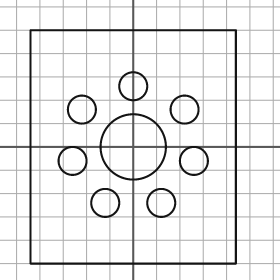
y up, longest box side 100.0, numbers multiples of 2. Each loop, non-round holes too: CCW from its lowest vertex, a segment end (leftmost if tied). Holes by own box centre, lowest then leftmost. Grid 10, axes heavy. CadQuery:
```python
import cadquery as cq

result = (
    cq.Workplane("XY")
    .moveTo(-44.0, -50.0)
    .lineTo(44.0, -50.0)
    .lineTo(44.0, 50.0)
    .lineTo(-44.0, 50.0)
    .close()
    .moveTo(-12.0, -24.0)
    .circle(6.0)
    .moveTo(12.0, -24.0)
    .circle(6.0)
    .moveTo(-26.0, -6.0)
    .circle(6.0)
    .moveTo(26.0, -6.0)
    .circle(6.0)
    .moveTo(0.0, 0.0)
    .circle(14.0)
    .moveTo(-22.0, 16.0)
    .circle(6.0)
    .moveTo(22.0, 16.0)
    .circle(6.0)
    .moveTo(0.0, 26.0)
    .circle(6.0)
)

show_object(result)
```